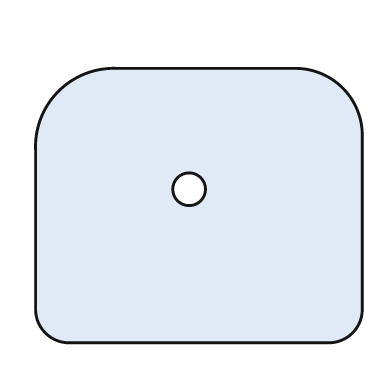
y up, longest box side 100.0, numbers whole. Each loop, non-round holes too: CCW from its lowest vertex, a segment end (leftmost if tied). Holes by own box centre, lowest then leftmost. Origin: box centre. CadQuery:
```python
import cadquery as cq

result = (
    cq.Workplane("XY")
    .moveTo(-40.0, -42.0)
    .lineTo(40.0, -42.0)
    .threePointArc((47.0, -39.0), (50.0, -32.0))
    .lineTo(50.0, 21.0)
    .threePointArc((44.0, 36.0), (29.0, 42.0))
    .lineTo(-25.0, 42.0)
    .threePointArc((-43.0, 35.0), (-50.0, 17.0))
    .lineTo(-50.0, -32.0)
    .threePointArc((-47.0, -39.0), (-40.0, -42.0))
    .close()
    .moveTo(-3.0, 5.0)
    .circle(5.0)
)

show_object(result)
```